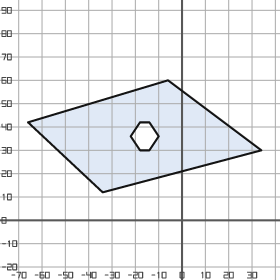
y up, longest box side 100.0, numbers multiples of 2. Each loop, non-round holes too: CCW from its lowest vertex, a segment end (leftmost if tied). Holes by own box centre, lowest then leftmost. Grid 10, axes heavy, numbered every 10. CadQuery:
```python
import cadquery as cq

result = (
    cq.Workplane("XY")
    .moveTo(-34.0, 12.0)
    .lineTo(34.0, 30.0)
    .lineTo(-6.0, 60.0)
    .lineTo(-66.0, 42.0)
    .close()
    .moveTo(-18.0, 30.0)
    .lineTo(-14.0, 30.0)
    .lineTo(-10.0, 36.0)
    .lineTo(-14.0, 42.0)
    .lineTo(-18.0, 42.0)
    .lineTo(-22.0, 36.0)
    .close()
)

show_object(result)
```